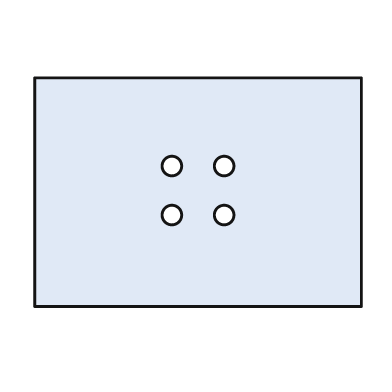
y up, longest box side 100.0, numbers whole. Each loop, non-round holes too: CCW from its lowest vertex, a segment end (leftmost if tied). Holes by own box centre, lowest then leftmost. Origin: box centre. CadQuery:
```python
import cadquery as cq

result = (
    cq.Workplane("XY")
    .moveTo(-50.0, -35.0)
    .lineTo(50.0, -35.0)
    .lineTo(50.0, 35.0)
    .lineTo(-50.0, 35.0)
    .close()
    .moveTo(-8.0, -7.0)
    .circle(3.0)
    .moveTo(8.0, -7.0)
    .circle(3.0)
    .moveTo(-8.0, 8.0)
    .circle(3.0)
    .moveTo(8.0, 8.0)
    .circle(3.0)
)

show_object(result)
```